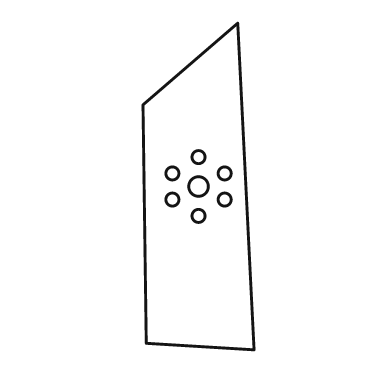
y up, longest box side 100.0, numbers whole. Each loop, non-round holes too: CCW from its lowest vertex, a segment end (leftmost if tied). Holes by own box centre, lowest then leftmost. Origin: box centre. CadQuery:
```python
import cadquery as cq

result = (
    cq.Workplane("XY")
    .moveTo(17.0, -50.0)
    .lineTo(12.0, 50.0)
    .lineTo(-17.0, 25.0)
    .lineTo(-16.0, -48.0)
    .close()
    .moveTo(0.0, -9.0)
    .circle(2.0)
    .moveTo(-8.0, -4.0)
    .circle(2.0)
    .moveTo(8.0, -4.0)
    .circle(2.0)
    .moveTo(0.0, 0.0)
    .circle(3.0)
    .moveTo(-8.0, 4.0)
    .circle(2.0)
    .moveTo(8.0, 4.0)
    .circle(2.0)
    .moveTo(0.0, 9.0)
    .circle(2.0)
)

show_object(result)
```